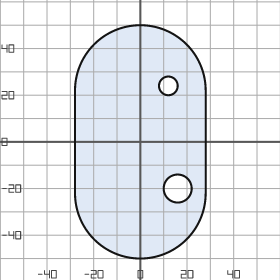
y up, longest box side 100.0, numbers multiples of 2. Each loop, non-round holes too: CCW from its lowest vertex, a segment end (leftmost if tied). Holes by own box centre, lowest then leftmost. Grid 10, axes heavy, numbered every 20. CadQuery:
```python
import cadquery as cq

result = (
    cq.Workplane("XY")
    .moveTo(-28.0, -22.0)
    .threePointArc((0.0, -50.0), (28.0, -22.0))
    .lineTo(28.0, 22.0)
    .threePointArc((0.0, 50.0), (-28.0, 22.0))
    .close()
    .moveTo(16.0, -20.0)
    .circle(6.0)
    .moveTo(12.0, 24.0)
    .circle(4.0)
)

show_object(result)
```